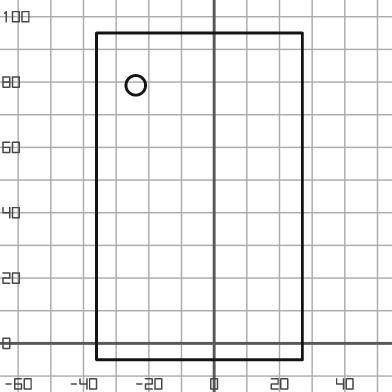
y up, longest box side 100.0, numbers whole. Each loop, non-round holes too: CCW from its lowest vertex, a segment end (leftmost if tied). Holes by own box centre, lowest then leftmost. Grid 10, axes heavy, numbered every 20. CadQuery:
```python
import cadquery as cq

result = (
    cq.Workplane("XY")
    .moveTo(-36.0, -5.0)
    .lineTo(27.0, -5.0)
    .lineTo(27.0, 95.0)
    .lineTo(-36.0, 95.0)
    .close()
    .moveTo(-24.0, 79.0)
    .circle(3.0)
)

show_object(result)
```